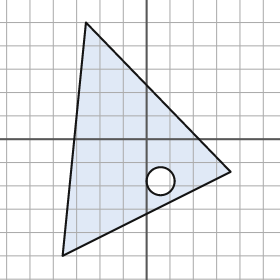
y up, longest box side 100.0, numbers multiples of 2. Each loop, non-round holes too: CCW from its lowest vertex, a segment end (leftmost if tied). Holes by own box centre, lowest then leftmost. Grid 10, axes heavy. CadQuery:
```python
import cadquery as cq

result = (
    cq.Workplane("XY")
    .moveTo(-36.0, -50.0)
    .lineTo(36.0, -14.0)
    .lineTo(-26.0, 50.0)
    .close()
    .moveTo(6.0, -18.0)
    .circle(6.0)
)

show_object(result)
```